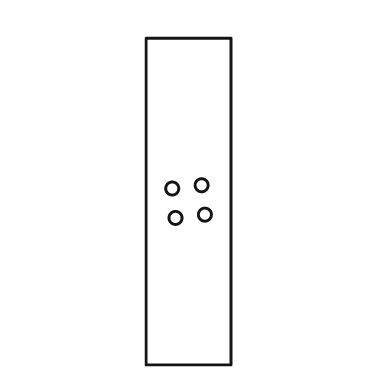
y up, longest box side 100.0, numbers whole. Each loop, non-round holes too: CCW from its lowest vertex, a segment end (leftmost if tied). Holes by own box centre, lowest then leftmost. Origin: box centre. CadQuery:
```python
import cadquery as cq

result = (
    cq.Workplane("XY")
    .moveTo(-13.0, -50.0)
    .lineTo(13.0, -50.0)
    .lineTo(13.0, 50.0)
    .lineTo(-13.0, 50.0)
    .close()
    .moveTo(-4.0, -5.0)
    .circle(2.0)
    .moveTo(5.0, -4.0)
    .circle(2.0)
    .moveTo(-5.0, 4.0)
    .circle(2.0)
    .moveTo(4.0, 5.0)
    .circle(2.0)
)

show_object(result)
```